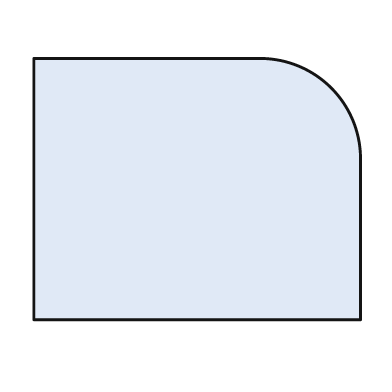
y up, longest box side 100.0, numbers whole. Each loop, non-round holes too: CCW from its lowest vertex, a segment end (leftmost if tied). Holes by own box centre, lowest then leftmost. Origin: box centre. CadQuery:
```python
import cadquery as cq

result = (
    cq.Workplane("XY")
    .moveTo(-50.0, -40.0)
    .lineTo(50.0, -40.0)
    .lineTo(50.0, 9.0)
    .threePointArc((41.0, 31.0), (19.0, 40.0))
    .lineTo(-50.0, 40.0)
    .close()
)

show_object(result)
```